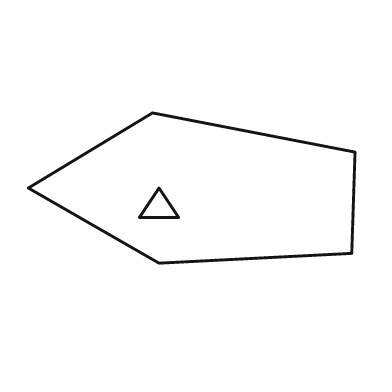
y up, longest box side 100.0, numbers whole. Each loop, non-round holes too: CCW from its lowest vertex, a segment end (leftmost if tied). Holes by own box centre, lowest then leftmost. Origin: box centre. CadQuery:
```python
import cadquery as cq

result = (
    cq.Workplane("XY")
    .moveTo(-10.0, -23.0)
    .lineTo(49.0, -20.0)
    .lineTo(50.0, 11.0)
    .lineTo(-12.0, 23.0)
    .lineTo(-50.0, 0.0)
    .close()
    .moveTo(-16.0, -9.0)
    .lineTo(-4.0, -9.0)
    .lineTo(-10.0, 0.0)
    .close()
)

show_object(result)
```